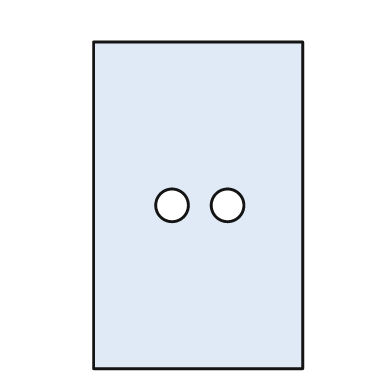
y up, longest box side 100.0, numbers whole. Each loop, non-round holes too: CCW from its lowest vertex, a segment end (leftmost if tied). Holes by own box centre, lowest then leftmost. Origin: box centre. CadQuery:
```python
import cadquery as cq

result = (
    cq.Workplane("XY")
    .moveTo(-32.0, -50.0)
    .lineTo(32.0, -50.0)
    .lineTo(32.0, 50.0)
    .lineTo(-32.0, 50.0)
    .close()
    .moveTo(-8.0, 0.0)
    .circle(5.0)
    .moveTo(9.0, 0.0)
    .circle(5.0)
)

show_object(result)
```